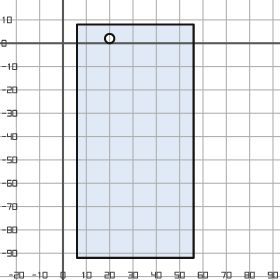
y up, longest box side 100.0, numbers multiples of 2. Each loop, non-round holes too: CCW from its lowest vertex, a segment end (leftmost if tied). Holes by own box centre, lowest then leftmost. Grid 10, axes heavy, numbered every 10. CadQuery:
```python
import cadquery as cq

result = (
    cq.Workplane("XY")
    .moveTo(6.0, -92.0)
    .lineTo(56.0, -92.0)
    .lineTo(56.0, 8.0)
    .lineTo(6.0, 8.0)
    .close()
    .moveTo(20.0, 2.0)
    .circle(2.0)
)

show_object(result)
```